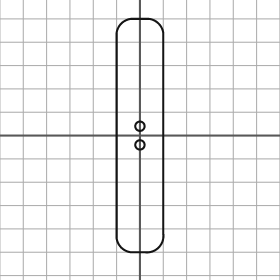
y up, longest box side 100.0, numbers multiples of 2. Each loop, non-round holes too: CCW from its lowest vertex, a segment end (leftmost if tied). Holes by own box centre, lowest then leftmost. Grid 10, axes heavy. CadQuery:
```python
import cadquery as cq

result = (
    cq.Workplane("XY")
    .moveTo(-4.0, -50.0)
    .lineTo(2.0, -50.0)
    .threePointArc((8.0, -48.0), (10.0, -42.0))
    .lineTo(10.0, 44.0)
    .threePointArc((8.0, 48.0), (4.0, 50.0))
    .lineTo(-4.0, 50.0)
    .threePointArc((-8.0, 48.0), (-10.0, 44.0))
    .lineTo(-10.0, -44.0)
    .threePointArc((-8.0, -48.0), (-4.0, -50.0))
    .close()
    .moveTo(0.0, -4.0)
    .circle(2.0)
    .moveTo(0.0, 4.0)
    .circle(2.0)
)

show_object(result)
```